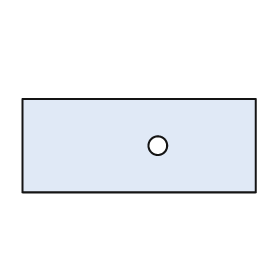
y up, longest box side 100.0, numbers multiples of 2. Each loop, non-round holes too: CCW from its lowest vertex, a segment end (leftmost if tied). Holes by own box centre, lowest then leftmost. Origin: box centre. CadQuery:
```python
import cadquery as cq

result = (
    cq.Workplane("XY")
    .moveTo(-50.0, -20.0)
    .lineTo(50.0, -20.0)
    .lineTo(50.0, 20.0)
    .lineTo(-50.0, 20.0)
    .close()
    .moveTo(8.0, 0.0)
    .circle(4.0)
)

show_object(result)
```